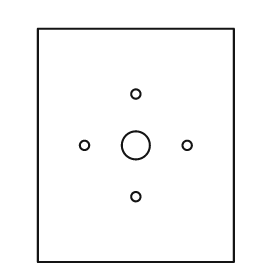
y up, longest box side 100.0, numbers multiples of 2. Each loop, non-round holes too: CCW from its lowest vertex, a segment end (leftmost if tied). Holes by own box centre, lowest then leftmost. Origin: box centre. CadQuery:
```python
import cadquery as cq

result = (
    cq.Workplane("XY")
    .moveTo(-42.0, -50.0)
    .lineTo(42.0, -50.0)
    .lineTo(42.0, 50.0)
    .lineTo(-42.0, 50.0)
    .close()
    .moveTo(0.0, -22.0)
    .circle(2.0)
    .moveTo(-22.0, 0.0)
    .circle(2.0)
    .moveTo(0.0, 0.0)
    .circle(6.0)
    .moveTo(22.0, 0.0)
    .circle(2.0)
    .moveTo(0.0, 22.0)
    .circle(2.0)
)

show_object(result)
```